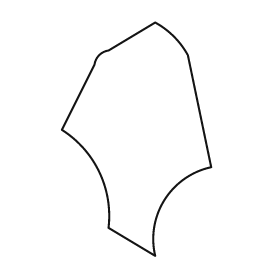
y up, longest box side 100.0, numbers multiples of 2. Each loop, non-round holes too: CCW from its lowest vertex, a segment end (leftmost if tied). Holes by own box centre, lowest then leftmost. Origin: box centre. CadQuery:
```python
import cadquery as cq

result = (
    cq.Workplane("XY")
    .moveTo(8.0, -50.0)
    .threePointArc((12.0, -26.0), (32.0, -12.0))
    .lineTo(22.0, 36.0)
    .threePointArc((16.0, 44.0), (8.0, 50.0))
    .lineTo(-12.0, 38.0)
    .threePointArc((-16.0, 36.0), (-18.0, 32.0))
    .lineTo(-32.0, 4.0)
    .threePointArc((-16.0, -14.0), (-12.0, -38.0))
    .close()
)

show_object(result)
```